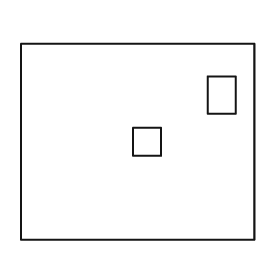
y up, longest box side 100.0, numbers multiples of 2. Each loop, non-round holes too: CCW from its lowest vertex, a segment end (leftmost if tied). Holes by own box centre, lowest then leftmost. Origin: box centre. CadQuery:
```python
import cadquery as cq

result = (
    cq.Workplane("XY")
    .moveTo(-50.0, -42.0)
    .lineTo(50.0, -42.0)
    .lineTo(50.0, 42.0)
    .lineTo(-50.0, 42.0)
    .close()
    .moveTo(-2.0, -6.0)
    .lineTo(10.0, -6.0)
    .lineTo(10.0, 6.0)
    .lineTo(-2.0, 6.0)
    .close()
    .moveTo(30.0, 12.0)
    .lineTo(42.0, 12.0)
    .lineTo(42.0, 28.0)
    .lineTo(30.0, 28.0)
    .close()
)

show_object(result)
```